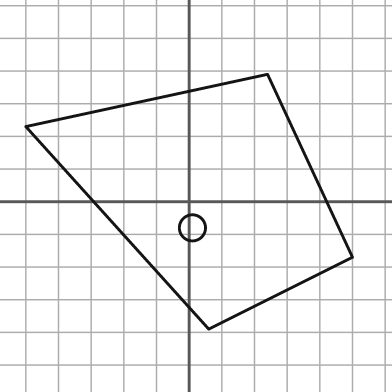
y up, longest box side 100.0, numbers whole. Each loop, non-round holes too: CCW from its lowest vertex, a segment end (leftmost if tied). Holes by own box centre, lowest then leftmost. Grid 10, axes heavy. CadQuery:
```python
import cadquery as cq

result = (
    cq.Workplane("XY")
    .moveTo(6.0, -39.0)
    .lineTo(50.0, -17.0)
    .lineTo(24.0, 39.0)
    .lineTo(-50.0, 23.0)
    .close()
    .moveTo(1.0, -8.0)
    .circle(4.0)
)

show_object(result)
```